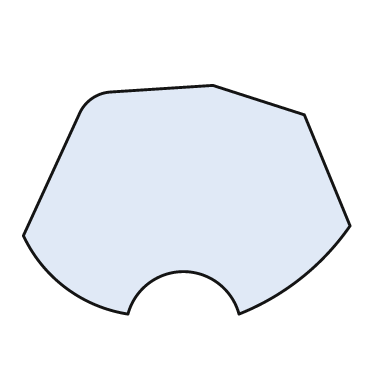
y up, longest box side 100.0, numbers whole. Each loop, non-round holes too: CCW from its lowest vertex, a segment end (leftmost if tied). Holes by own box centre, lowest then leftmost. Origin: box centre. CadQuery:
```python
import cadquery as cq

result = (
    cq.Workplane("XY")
    .moveTo(-18.0, -35.0)
    .threePointArc((-1.0, -22.0), (16.0, -35.0))
    .threePointArc((35.0, -24.0), (50.0, -8.0))
    .lineTo(36.0, 26.0)
    .lineTo(8.0, 35.0)
    .lineTo(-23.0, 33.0)
    .threePointArc((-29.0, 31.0), (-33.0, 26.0))
    .lineTo(-50.0, -11.0)
    .threePointArc((-37.0, -27.0), (-18.0, -35.0))
    .close()
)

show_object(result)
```